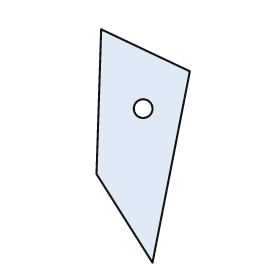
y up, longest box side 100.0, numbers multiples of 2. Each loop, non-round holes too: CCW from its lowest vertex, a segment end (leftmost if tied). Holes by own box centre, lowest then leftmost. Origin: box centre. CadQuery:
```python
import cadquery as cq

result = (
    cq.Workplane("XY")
    .moveTo(4.0, -50.0)
    .lineTo(20.0, 32.0)
    .lineTo(-18.0, 50.0)
    .lineTo(-20.0, -12.0)
    .close()
    .moveTo(0.0, 16.0)
    .circle(4.0)
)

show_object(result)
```